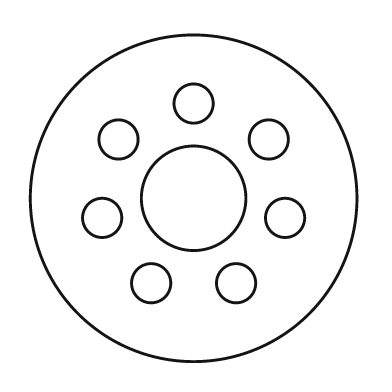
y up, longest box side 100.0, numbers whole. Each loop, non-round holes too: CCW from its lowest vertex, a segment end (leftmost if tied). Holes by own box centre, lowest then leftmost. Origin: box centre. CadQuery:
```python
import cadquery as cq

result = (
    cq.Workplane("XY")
    .moveTo(0.0, 0.0)
    .circle(50.0)
    .moveTo(-13.0, -26.0)
    .circle(6.0)
    .moveTo(13.0, -26.0)
    .circle(6.0)
    .moveTo(-28.0, -6.0)
    .circle(6.0)
    .moveTo(28.0, -6.0)
    .circle(6.0)
    .moveTo(0.0, 0.0)
    .circle(16.0)
    .moveTo(-23.0, 18.0)
    .circle(6.0)
    .moveTo(23.0, 18.0)
    .circle(6.0)
    .moveTo(0.0, 29.0)
    .circle(6.0)
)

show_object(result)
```